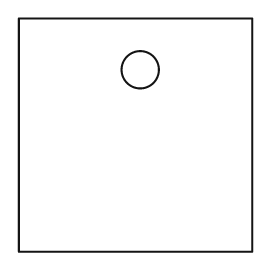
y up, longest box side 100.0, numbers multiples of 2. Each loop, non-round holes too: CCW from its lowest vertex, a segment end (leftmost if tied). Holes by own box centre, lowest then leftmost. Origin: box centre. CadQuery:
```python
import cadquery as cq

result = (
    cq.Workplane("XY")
    .moveTo(-50.0, -50.0)
    .lineTo(50.0, -50.0)
    .lineTo(50.0, 50.0)
    .lineTo(-50.0, 50.0)
    .close()
    .moveTo(2.0, 28.0)
    .circle(8.0)
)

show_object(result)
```